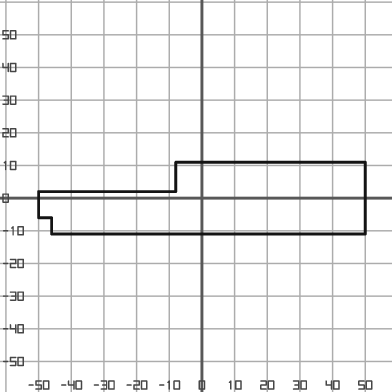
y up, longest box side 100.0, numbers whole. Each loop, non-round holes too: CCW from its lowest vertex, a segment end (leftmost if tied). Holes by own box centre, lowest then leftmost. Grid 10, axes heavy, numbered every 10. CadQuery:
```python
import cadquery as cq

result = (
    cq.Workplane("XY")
    .moveTo(-46.0, -11.0)
    .lineTo(50.0, -11.0)
    .lineTo(50.0, 11.0)
    .lineTo(-8.0, 11.0)
    .lineTo(-8.0, 2.0)
    .lineTo(-50.0, 2.0)
    .lineTo(-50.0, -6.0)
    .lineTo(-46.0, -6.0)
    .close()
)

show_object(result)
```